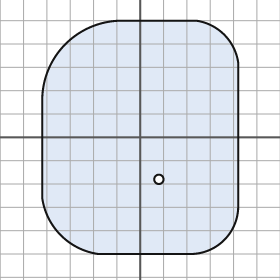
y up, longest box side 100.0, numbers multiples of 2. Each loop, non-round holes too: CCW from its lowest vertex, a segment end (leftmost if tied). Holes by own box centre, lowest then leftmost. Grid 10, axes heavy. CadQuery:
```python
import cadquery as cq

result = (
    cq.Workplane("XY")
    .moveTo(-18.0, -50.0)
    .lineTo(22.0, -50.0)
    .threePointArc((36.0, -44.0), (42.0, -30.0))
    .lineTo(42.0, 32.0)
    .threePointArc((36.0, 44.0), (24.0, 50.0))
    .lineTo(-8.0, 50.0)
    .threePointArc((-32.0, 40.0), (-42.0, 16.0))
    .lineTo(-42.0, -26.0)
    .threePointArc((-34.0, -42.0), (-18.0, -50.0))
    .close()
    .moveTo(8.0, -18.0)
    .circle(2.0)
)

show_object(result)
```